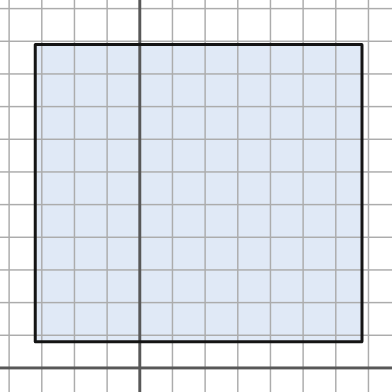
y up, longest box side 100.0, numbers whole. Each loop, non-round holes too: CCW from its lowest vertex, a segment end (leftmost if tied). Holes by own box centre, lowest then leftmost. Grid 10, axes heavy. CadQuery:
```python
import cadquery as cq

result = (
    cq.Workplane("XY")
    .moveTo(-32.0, 8.0)
    .lineTo(68.0, 8.0)
    .lineTo(68.0, 99.0)
    .lineTo(-32.0, 99.0)
    .close()
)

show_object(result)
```